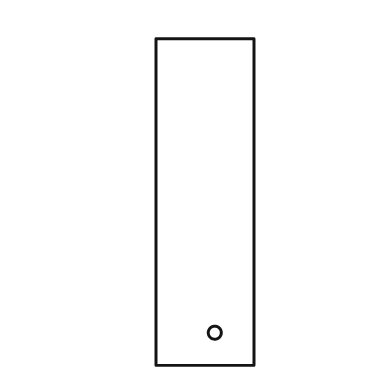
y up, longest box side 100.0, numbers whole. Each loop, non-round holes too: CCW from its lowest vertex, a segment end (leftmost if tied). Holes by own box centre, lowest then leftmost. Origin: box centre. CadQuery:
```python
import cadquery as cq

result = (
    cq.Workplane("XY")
    .moveTo(-15.0, -50.0)
    .lineTo(15.0, -50.0)
    .lineTo(15.0, 50.0)
    .lineTo(-15.0, 50.0)
    .close()
    .moveTo(3.0, -40.0)
    .circle(2.0)
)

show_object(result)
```